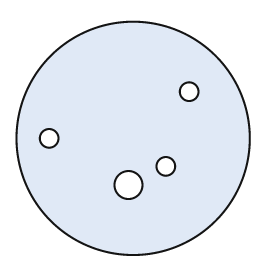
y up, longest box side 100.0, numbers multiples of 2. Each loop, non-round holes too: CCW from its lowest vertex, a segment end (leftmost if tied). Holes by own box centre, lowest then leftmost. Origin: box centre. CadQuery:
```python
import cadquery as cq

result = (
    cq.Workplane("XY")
    .moveTo(0.0, 0.0)
    .circle(50.0)
    .moveTo(-2.0, -20.0)
    .circle(6.0)
    .moveTo(14.0, -12.0)
    .circle(4.0)
    .moveTo(-36.0, 0.0)
    .circle(4.0)
    .moveTo(24.0, 20.0)
    .circle(4.0)
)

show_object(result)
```